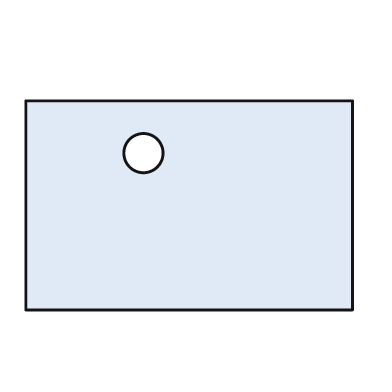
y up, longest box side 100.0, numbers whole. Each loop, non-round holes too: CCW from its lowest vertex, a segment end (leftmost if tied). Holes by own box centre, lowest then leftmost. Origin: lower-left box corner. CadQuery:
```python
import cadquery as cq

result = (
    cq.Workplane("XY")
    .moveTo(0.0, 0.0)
    .lineTo(100.0, 0.0)
    .lineTo(100.0, 64.0)
    .lineTo(0.0, 64.0)
    .close()
    .moveTo(36.0, 48.0)
    .circle(6.0)
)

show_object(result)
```